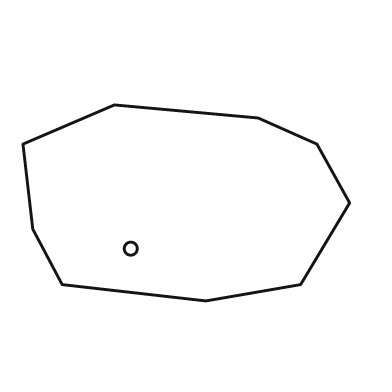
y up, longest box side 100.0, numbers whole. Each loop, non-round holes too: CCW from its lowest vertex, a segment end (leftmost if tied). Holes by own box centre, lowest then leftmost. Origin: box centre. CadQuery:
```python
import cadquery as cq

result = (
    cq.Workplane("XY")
    .moveTo(6.0, -30.0)
    .lineTo(35.0, -25.0)
    .lineTo(50.0, 0.0)
    .lineTo(40.0, 18.0)
    .lineTo(22.0, 26.0)
    .lineTo(-22.0, 30.0)
    .lineTo(-50.0, 18.0)
    .lineTo(-47.0, -8.0)
    .lineTo(-38.0, -25.0)
    .close()
    .moveTo(-17.0, -14.0)
    .circle(2.0)
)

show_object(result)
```